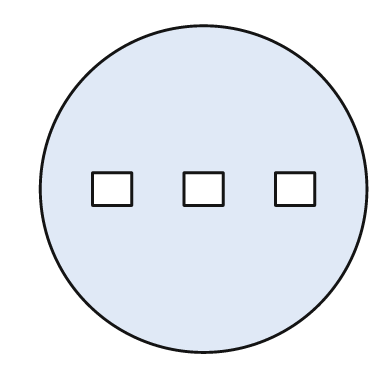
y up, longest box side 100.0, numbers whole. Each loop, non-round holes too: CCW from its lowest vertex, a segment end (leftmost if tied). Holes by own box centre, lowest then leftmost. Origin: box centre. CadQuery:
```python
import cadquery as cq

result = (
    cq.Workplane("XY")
    .moveTo(0.0, 0.0)
    .circle(50.0)
    .moveTo(-34.0, -5.0)
    .lineTo(-22.0, -5.0)
    .lineTo(-22.0, 5.0)
    .lineTo(-34.0, 5.0)
    .close()
    .moveTo(-6.0, -5.0)
    .lineTo(6.0, -5.0)
    .lineTo(6.0, 5.0)
    .lineTo(-6.0, 5.0)
    .close()
    .moveTo(22.0, -5.0)
    .lineTo(34.0, -5.0)
    .lineTo(34.0, 5.0)
    .lineTo(22.0, 5.0)
    .close()
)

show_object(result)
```